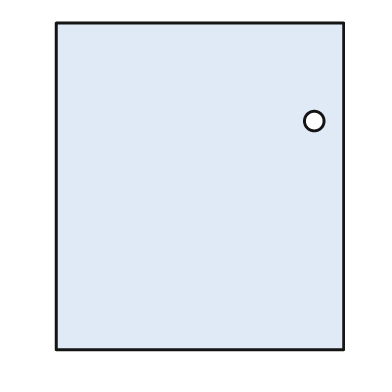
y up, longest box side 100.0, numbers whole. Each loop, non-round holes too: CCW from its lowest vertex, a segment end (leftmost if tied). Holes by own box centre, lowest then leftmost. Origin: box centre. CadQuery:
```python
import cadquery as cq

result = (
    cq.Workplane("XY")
    .moveTo(-44.0, -50.0)
    .lineTo(44.0, -50.0)
    .lineTo(44.0, 50.0)
    .lineTo(-44.0, 50.0)
    .close()
    .moveTo(35.0, 20.0)
    .circle(3.0)
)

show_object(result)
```